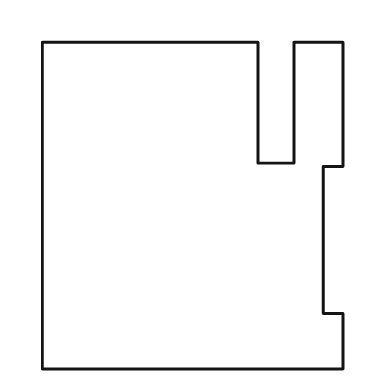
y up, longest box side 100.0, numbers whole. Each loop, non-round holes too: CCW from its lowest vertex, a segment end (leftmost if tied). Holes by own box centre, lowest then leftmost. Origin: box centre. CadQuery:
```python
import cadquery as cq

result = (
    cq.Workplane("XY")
    .moveTo(-46.0, -50.0)
    .lineTo(46.0, -50.0)
    .lineTo(46.0, -33.0)
    .lineTo(40.0, -33.0)
    .lineTo(40.0, 12.0)
    .lineTo(46.0, 12.0)
    .lineTo(46.0, 50.0)
    .lineTo(31.0, 50.0)
    .lineTo(31.0, 13.0)
    .lineTo(20.0, 13.0)
    .lineTo(20.0, 50.0)
    .lineTo(-46.0, 50.0)
    .close()
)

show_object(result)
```